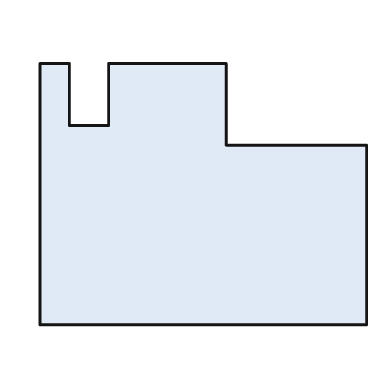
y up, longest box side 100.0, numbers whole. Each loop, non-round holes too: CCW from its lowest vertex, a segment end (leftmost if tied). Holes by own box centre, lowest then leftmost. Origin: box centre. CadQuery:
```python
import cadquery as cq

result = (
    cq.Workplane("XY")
    .moveTo(-50.0, -40.0)
    .lineTo(50.0, -40.0)
    .lineTo(50.0, 15.0)
    .lineTo(7.0, 15.0)
    .lineTo(7.0, 40.0)
    .lineTo(-29.0, 40.0)
    .lineTo(-29.0, 21.0)
    .lineTo(-41.0, 21.0)
    .lineTo(-41.0, 40.0)
    .lineTo(-50.0, 40.0)
    .close()
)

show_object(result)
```